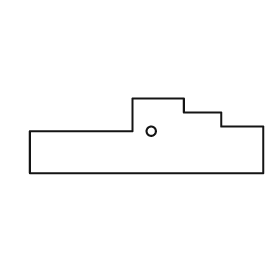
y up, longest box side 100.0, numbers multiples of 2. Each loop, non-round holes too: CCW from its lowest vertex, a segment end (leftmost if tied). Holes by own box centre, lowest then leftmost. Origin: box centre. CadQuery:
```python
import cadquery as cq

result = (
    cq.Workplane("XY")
    .moveTo(-50.0, -16.0)
    .lineTo(50.0, -16.0)
    .lineTo(50.0, 4.0)
    .lineTo(32.0, 4.0)
    .lineTo(32.0, 10.0)
    .lineTo(16.0, 10.0)
    .lineTo(16.0, 16.0)
    .lineTo(-6.0, 16.0)
    .lineTo(-6.0, 2.0)
    .lineTo(-50.0, 2.0)
    .close()
    .moveTo(2.0, 2.0)
    .circle(2.0)
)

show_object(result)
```